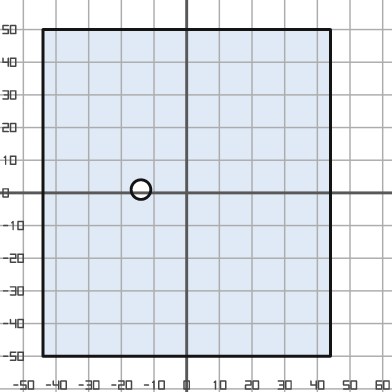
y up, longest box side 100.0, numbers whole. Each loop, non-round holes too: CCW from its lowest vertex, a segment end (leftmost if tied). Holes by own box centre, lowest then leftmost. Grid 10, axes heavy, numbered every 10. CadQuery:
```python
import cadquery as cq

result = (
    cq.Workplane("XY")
    .moveTo(-44.0, -50.0)
    .lineTo(44.0, -50.0)
    .lineTo(44.0, 50.0)
    .lineTo(-44.0, 50.0)
    .close()
    .moveTo(-14.0, 1.0)
    .circle(3.0)
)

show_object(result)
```